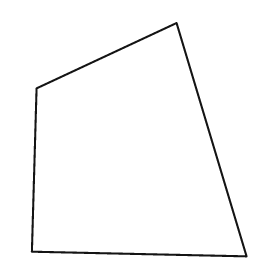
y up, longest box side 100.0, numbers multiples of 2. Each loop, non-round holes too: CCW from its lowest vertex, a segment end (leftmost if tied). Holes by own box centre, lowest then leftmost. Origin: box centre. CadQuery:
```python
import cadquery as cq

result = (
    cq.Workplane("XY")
    .moveTo(46.0, -50.0)
    .lineTo(16.0, 50.0)
    .lineTo(-44.0, 22.0)
    .lineTo(-46.0, -48.0)
    .close()
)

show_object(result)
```